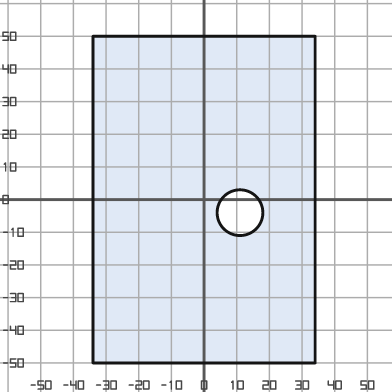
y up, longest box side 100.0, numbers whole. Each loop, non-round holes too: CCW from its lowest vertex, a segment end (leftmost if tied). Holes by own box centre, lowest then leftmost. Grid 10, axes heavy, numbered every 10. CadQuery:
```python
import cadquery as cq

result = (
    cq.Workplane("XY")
    .moveTo(-34.0, -50.0)
    .lineTo(34.0, -50.0)
    .lineTo(34.0, 50.0)
    .lineTo(-34.0, 50.0)
    .close()
    .moveTo(11.0, -4.0)
    .circle(7.0)
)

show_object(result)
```